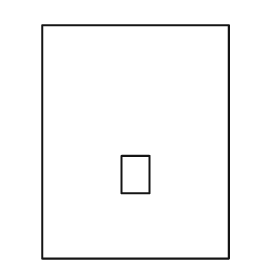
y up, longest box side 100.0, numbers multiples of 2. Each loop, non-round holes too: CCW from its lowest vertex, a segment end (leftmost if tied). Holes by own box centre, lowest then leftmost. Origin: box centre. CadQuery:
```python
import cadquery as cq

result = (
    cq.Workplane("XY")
    .moveTo(-40.0, -50.0)
    .lineTo(40.0, -50.0)
    .lineTo(40.0, 50.0)
    .lineTo(-40.0, 50.0)
    .close()
    .moveTo(-6.0, -22.0)
    .lineTo(6.0, -22.0)
    .lineTo(6.0, -6.0)
    .lineTo(-6.0, -6.0)
    .close()
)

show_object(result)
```